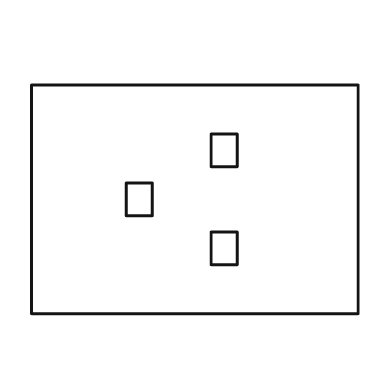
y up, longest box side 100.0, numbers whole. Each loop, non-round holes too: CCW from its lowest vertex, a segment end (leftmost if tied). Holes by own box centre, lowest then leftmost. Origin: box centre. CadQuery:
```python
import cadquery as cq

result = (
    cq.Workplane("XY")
    .moveTo(-50.0, -35.0)
    .lineTo(50.0, -35.0)
    .lineTo(50.0, 35.0)
    .lineTo(-50.0, 35.0)
    .close()
    .moveTo(5.0, -20.0)
    .lineTo(13.0, -20.0)
    .lineTo(13.0, -10.0)
    .lineTo(5.0, -10.0)
    .close()
    .moveTo(-21.0, -5.0)
    .lineTo(-13.0, -5.0)
    .lineTo(-13.0, 5.0)
    .lineTo(-21.0, 5.0)
    .close()
    .moveTo(5.0, 10.0)
    .lineTo(13.0, 10.0)
    .lineTo(13.0, 20.0)
    .lineTo(5.0, 20.0)
    .close()
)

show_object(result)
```